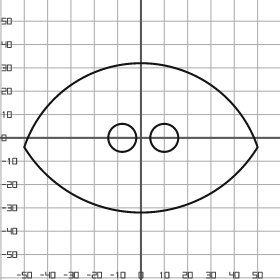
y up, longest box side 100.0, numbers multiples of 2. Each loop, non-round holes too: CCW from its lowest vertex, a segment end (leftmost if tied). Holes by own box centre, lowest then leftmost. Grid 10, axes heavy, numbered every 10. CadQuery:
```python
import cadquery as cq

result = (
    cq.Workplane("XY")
    .moveTo(-50.0, -4.0)
    .threePointArc((0.0, -32.0), (50.0, -4.0))
    .threePointArc((0.0, 32.0), (-50.0, -4.0))
    .close()
    .moveTo(-8.0, 0.0)
    .circle(6.0)
    .moveTo(10.0, 0.0)
    .circle(6.0)
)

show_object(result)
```